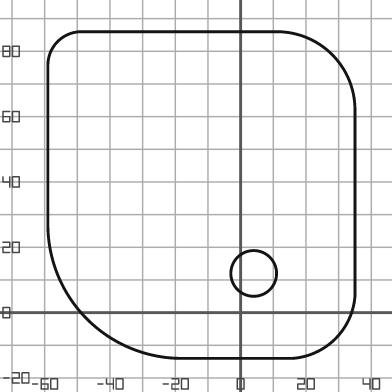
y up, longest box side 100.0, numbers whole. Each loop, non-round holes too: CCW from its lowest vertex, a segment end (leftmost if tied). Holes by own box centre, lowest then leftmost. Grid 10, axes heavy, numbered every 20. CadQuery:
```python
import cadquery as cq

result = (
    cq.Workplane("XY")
    .moveTo(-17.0, -14.0)
    .lineTo(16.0, -14.0)
    .threePointArc((29.0, -8.0), (35.0, 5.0))
    .lineTo(35.0, 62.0)
    .threePointArc((28.0, 79.0), (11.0, 86.0))
    .lineTo(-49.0, 86.0)
    .threePointArc((-56.0, 83.0), (-59.0, 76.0))
    .lineTo(-59.0, 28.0)
    .threePointArc((-47.0, -2.0), (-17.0, -14.0))
    .close()
    .moveTo(4.0, 12.0)
    .circle(7.0)
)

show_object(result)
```